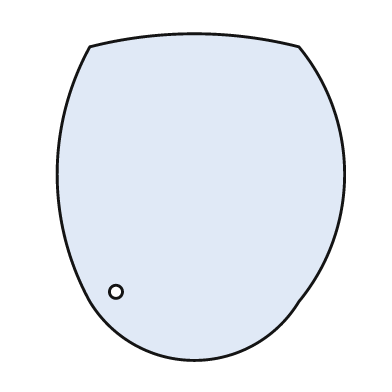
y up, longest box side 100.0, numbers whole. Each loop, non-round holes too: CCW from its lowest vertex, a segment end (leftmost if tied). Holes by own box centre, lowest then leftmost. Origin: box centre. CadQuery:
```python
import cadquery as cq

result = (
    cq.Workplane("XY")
    .moveTo(-34.0, -32.0)
    .threePointArc((-2.0, -50.0), (30.0, -32.0))
    .threePointArc((44.0, 7.0), (30.0, 46.0))
    .threePointArc((-2.0, 50.0), (-34.0, 46.0))
    .threePointArc((-44.0, 7.0), (-34.0, -32.0))
    .close()
    .moveTo(-26.0, -29.0)
    .circle(2.0)
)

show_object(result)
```